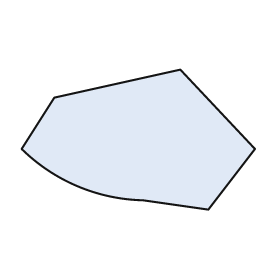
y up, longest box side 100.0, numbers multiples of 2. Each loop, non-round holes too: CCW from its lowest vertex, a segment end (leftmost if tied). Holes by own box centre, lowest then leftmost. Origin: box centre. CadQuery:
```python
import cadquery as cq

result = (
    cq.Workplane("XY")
    .moveTo(30.0, -30.0)
    .lineTo(50.0, -4.0)
    .lineTo(18.0, 30.0)
    .lineTo(-36.0, 18.0)
    .lineTo(-50.0, -4.0)
    .threePointArc((-26.0, -20.0), (2.0, -26.0))
    .close()
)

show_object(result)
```